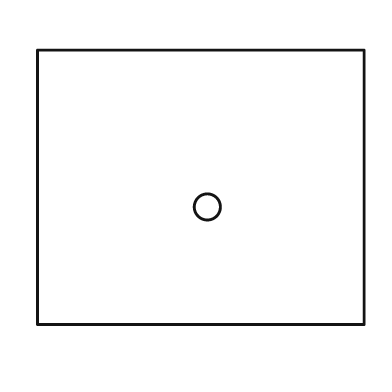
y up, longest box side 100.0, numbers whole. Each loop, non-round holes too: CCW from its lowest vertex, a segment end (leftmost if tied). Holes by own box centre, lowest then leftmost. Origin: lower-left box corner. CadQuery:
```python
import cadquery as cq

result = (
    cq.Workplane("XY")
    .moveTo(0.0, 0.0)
    .lineTo(100.0, 0.0)
    .lineTo(100.0, 84.0)
    .lineTo(0.0, 84.0)
    .close()
    .moveTo(52.0, 36.0)
    .circle(4.0)
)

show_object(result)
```